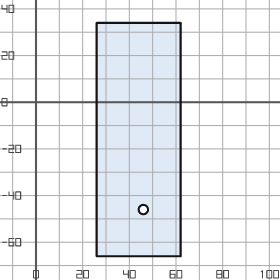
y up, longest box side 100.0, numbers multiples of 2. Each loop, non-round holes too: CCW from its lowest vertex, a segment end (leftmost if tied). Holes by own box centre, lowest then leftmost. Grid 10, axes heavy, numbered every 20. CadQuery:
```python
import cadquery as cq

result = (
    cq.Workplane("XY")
    .moveTo(26.0, -66.0)
    .lineTo(62.0, -66.0)
    .lineTo(62.0, 34.0)
    .lineTo(26.0, 34.0)
    .close()
    .moveTo(46.0, -46.0)
    .circle(2.0)
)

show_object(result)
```